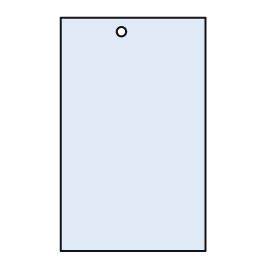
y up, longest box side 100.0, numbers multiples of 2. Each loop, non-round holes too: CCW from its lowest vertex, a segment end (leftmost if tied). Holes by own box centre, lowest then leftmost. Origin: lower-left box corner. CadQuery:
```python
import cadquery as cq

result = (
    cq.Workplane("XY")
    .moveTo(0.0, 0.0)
    .lineTo(62.0, 0.0)
    .lineTo(62.0, 100.0)
    .lineTo(0.0, 100.0)
    .close()
    .moveTo(26.0, 94.0)
    .circle(2.0)
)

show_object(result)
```